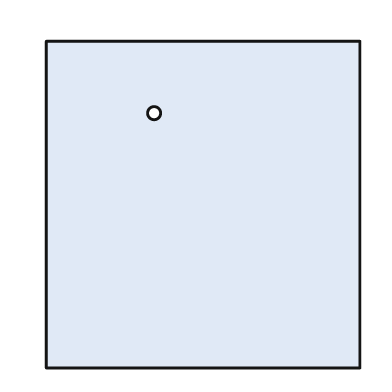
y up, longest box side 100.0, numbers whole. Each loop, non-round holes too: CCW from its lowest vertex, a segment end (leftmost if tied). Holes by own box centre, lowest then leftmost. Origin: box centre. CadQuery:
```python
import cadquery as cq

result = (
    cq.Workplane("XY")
    .moveTo(-48.0, -50.0)
    .lineTo(48.0, -50.0)
    .lineTo(48.0, 50.0)
    .lineTo(-48.0, 50.0)
    .close()
    .moveTo(-15.0, 28.0)
    .circle(2.0)
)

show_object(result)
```